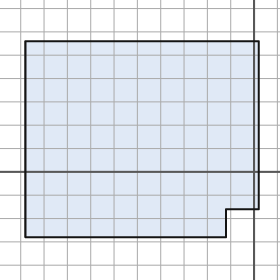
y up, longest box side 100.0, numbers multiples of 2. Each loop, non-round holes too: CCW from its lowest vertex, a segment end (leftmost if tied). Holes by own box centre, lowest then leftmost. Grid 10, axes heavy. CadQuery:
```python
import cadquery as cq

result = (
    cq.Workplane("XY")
    .moveTo(-98.0, -28.0)
    .lineTo(-12.0, -28.0)
    .lineTo(-12.0, -16.0)
    .lineTo(2.0, -16.0)
    .lineTo(2.0, 56.0)
    .lineTo(-98.0, 56.0)
    .close()
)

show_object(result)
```